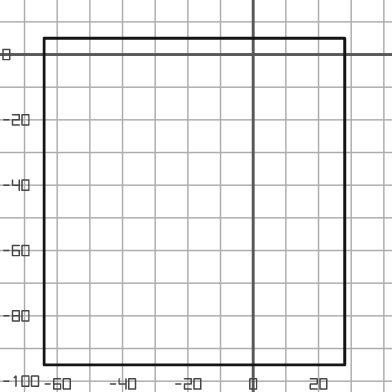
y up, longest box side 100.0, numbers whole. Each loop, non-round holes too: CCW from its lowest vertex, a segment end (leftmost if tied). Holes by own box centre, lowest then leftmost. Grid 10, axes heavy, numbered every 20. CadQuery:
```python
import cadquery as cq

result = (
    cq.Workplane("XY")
    .moveTo(-64.0, -95.0)
    .lineTo(28.0, -95.0)
    .lineTo(28.0, 5.0)
    .lineTo(-64.0, 5.0)
    .close()
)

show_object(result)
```